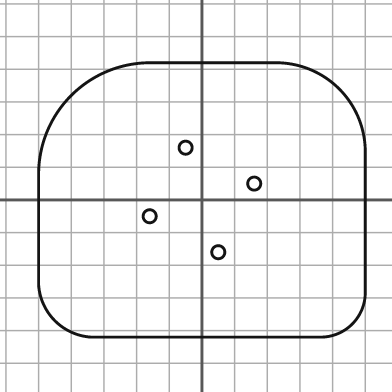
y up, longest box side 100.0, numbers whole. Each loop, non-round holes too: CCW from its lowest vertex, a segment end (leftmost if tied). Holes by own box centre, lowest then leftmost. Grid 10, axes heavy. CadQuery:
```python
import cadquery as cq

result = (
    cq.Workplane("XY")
    .moveTo(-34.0, -42.0)
    .lineTo(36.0, -42.0)
    .threePointArc((46.0, -38.0), (50.0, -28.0))
    .lineTo(50.0, 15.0)
    .threePointArc((42.0, 34.0), (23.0, 42.0))
    .lineTo(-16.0, 42.0)
    .threePointArc((-40.0, 32.0), (-50.0, 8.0))
    .lineTo(-50.0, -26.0)
    .threePointArc((-45.0, -37.0), (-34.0, -42.0))
    .close()
    .moveTo(5.0, -16.0)
    .circle(2.0)
    .moveTo(-16.0, -5.0)
    .circle(2.0)
    .moveTo(16.0, 5.0)
    .circle(2.0)
    .moveTo(-5.0, 16.0)
    .circle(2.0)
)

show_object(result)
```